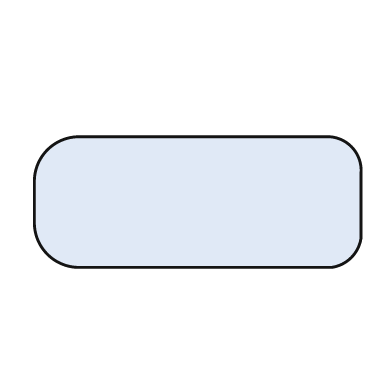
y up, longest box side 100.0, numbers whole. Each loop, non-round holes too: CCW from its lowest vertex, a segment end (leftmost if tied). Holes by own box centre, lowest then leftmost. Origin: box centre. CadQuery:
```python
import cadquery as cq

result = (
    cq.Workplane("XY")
    .moveTo(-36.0, -20.0)
    .lineTo(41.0, -20.0)
    .threePointArc((47.0, -17.0), (50.0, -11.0))
    .lineTo(50.0, 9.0)
    .threePointArc((47.0, 17.0), (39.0, 20.0))
    .lineTo(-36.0, 20.0)
    .threePointArc((-46.0, 16.0), (-50.0, 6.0))
    .lineTo(-50.0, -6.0)
    .threePointArc((-46.0, -16.0), (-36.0, -20.0))
    .close()
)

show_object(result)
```